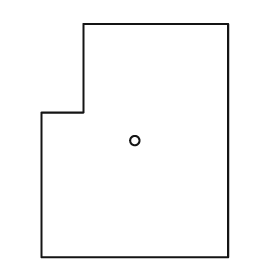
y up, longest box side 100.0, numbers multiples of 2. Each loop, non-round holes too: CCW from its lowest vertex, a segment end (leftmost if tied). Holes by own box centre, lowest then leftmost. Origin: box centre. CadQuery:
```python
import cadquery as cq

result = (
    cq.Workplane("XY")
    .moveTo(-40.0, -50.0)
    .lineTo(40.0, -50.0)
    .lineTo(40.0, 50.0)
    .lineTo(-22.0, 50.0)
    .lineTo(-22.0, 12.0)
    .lineTo(-40.0, 12.0)
    .close()
    .moveTo(0.0, 0.0)
    .circle(2.0)
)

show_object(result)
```